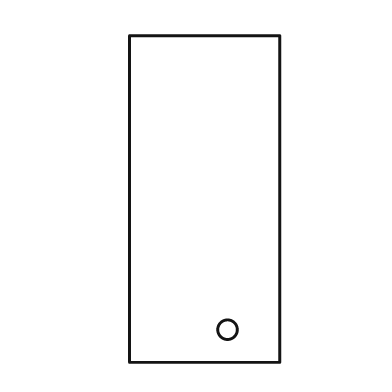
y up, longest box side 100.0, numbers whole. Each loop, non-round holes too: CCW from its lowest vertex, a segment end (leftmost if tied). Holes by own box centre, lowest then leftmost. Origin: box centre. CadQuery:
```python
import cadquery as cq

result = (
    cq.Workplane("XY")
    .moveTo(-23.0, -50.0)
    .lineTo(23.0, -50.0)
    .lineTo(23.0, 50.0)
    .lineTo(-23.0, 50.0)
    .close()
    .moveTo(7.0, -40.0)
    .circle(3.0)
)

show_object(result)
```